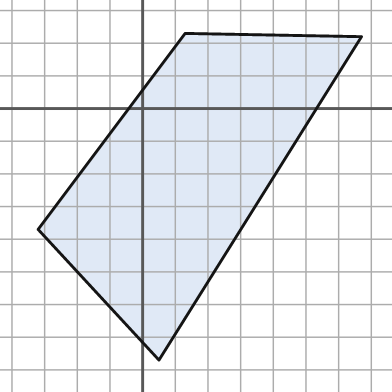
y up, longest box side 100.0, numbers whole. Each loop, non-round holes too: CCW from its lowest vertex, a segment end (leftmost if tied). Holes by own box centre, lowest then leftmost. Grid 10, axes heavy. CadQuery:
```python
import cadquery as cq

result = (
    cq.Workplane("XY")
    .moveTo(5.0, -77.0)
    .lineTo(67.0, 22.0)
    .lineTo(13.0, 23.0)
    .lineTo(-32.0, -37.0)
    .close()
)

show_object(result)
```